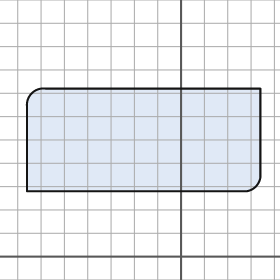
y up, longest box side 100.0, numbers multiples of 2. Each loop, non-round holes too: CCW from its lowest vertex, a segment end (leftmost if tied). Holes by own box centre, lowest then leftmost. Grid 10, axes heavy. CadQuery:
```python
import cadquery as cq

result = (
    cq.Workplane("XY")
    .moveTo(-66.0, 28.0)
    .lineTo(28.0, 28.0)
    .threePointArc((32.0, 30.0), (34.0, 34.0))
    .lineTo(34.0, 72.0)
    .lineTo(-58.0, 72.0)
    .threePointArc((-64.0, 70.0), (-66.0, 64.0))
    .close()
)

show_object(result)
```